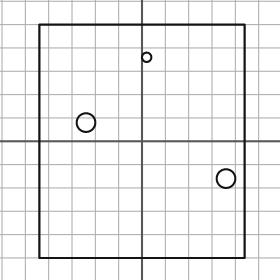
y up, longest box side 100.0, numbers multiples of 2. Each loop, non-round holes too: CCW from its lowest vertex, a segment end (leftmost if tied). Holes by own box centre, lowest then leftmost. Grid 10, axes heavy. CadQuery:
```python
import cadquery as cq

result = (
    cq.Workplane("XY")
    .moveTo(-44.0, -50.0)
    .lineTo(44.0, -50.0)
    .lineTo(44.0, 50.0)
    .lineTo(-44.0, 50.0)
    .close()
    .moveTo(36.0, -16.0)
    .circle(4.0)
    .moveTo(-24.0, 8.0)
    .circle(4.0)
    .moveTo(2.0, 36.0)
    .circle(2.0)
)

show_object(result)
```